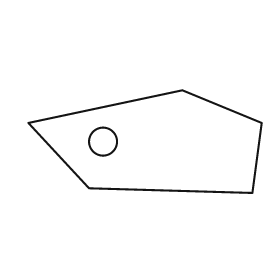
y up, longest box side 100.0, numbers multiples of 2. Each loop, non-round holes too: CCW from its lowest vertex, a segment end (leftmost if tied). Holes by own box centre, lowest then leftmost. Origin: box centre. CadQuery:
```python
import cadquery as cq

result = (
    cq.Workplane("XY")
    .moveTo(46.0, -22.0)
    .lineTo(50.0, 8.0)
    .lineTo(16.0, 22.0)
    .lineTo(-50.0, 8.0)
    .lineTo(-24.0, -20.0)
    .close()
    .moveTo(-18.0, 0.0)
    .circle(6.0)
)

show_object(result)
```